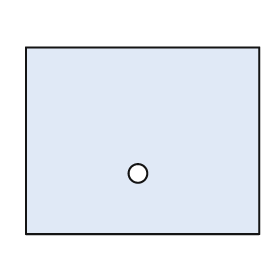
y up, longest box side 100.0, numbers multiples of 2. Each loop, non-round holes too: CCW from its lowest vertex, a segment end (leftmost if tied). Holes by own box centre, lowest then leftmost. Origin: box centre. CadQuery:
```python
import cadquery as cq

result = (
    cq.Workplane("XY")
    .moveTo(-50.0, -40.0)
    .lineTo(50.0, -40.0)
    .lineTo(50.0, 40.0)
    .lineTo(-50.0, 40.0)
    .close()
    .moveTo(-2.0, -14.0)
    .circle(4.0)
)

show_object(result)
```